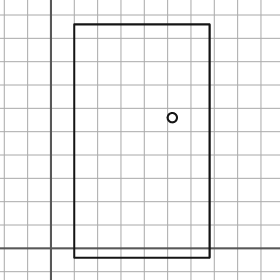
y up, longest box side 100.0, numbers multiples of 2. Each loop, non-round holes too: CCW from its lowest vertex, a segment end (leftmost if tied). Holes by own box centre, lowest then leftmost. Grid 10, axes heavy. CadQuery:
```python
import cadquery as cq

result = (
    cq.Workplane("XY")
    .moveTo(10.0, -4.0)
    .lineTo(68.0, -4.0)
    .lineTo(68.0, 96.0)
    .lineTo(10.0, 96.0)
    .close()
    .moveTo(52.0, 56.0)
    .circle(2.0)
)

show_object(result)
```